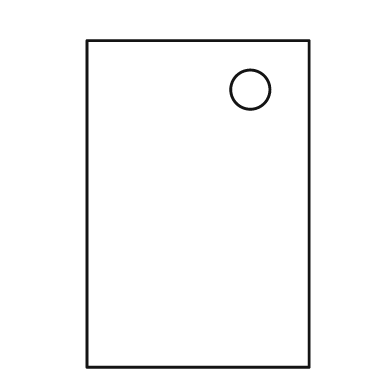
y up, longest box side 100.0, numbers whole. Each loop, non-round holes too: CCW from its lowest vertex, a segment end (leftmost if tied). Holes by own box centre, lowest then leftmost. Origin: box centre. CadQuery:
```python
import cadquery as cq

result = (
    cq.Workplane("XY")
    .moveTo(-34.0, -50.0)
    .lineTo(34.0, -50.0)
    .lineTo(34.0, 50.0)
    .lineTo(-34.0, 50.0)
    .close()
    .moveTo(16.0, 35.0)
    .circle(6.0)
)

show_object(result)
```